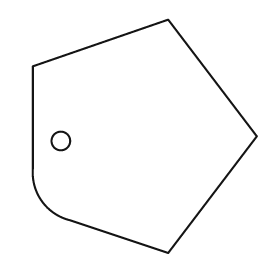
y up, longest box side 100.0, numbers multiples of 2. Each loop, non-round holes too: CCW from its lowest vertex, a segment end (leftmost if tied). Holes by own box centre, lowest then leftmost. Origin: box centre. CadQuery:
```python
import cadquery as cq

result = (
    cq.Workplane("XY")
    .moveTo(10.0, -50.0)
    .lineTo(48.0, 0.0)
    .lineTo(10.0, 50.0)
    .lineTo(-48.0, 30.0)
    .lineTo(-48.0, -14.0)
    .threePointArc((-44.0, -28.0), (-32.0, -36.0))
    .close()
    .moveTo(-36.0, -2.0)
    .circle(4.0)
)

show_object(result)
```